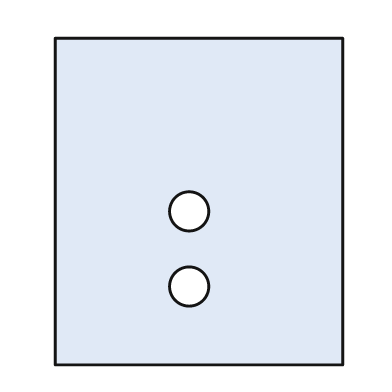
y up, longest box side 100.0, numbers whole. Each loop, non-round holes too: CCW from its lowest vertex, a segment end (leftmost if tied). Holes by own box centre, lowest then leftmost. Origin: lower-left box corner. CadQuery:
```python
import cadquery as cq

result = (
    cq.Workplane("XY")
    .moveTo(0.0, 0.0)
    .lineTo(88.0, 0.0)
    .lineTo(88.0, 100.0)
    .lineTo(0.0, 100.0)
    .close()
    .moveTo(41.0, 24.0)
    .circle(6.0)
    .moveTo(41.0, 47.0)
    .circle(6.0)
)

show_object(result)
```